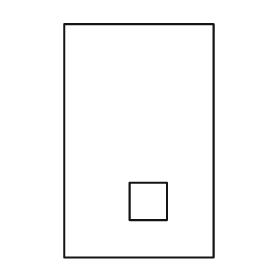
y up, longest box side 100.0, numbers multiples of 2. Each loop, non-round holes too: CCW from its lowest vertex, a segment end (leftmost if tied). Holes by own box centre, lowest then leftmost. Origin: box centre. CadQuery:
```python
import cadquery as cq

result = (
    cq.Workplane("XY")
    .moveTo(-32.0, -50.0)
    .lineTo(32.0, -50.0)
    .lineTo(32.0, 50.0)
    .lineTo(-32.0, 50.0)
    .close()
    .moveTo(-4.0, -34.0)
    .lineTo(12.0, -34.0)
    .lineTo(12.0, -18.0)
    .lineTo(-4.0, -18.0)
    .close()
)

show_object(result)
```